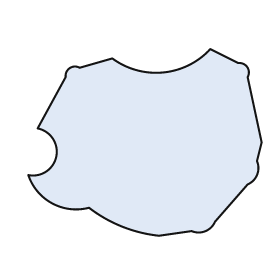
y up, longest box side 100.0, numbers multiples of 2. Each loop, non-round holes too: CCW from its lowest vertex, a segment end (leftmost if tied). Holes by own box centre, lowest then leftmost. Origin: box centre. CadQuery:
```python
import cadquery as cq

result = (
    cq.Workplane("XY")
    .moveTo(6.0, -40.0)
    .lineTo(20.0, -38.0)
    .threePointArc((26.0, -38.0), (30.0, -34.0))
    .lineTo(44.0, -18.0)
    .threePointArc((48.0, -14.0), (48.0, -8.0))
    .lineTo(50.0, 0.0)
    .lineTo(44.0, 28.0)
    .threePointArc((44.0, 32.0), (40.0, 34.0))
    .lineTo(28.0, 40.0)
    .threePointArc((8.0, 30.0), (-14.0, 36.0))
    .lineTo(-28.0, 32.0)
    .threePointArc((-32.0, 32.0), (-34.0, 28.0))
    .lineTo(-46.0, 6.0)
    .threePointArc((-38.0, -6.0), (-50.0, -14.0))
    .threePointArc((-40.0, -26.0), (-24.0, -28.0))
    .threePointArc((-10.0, -36.0), (6.0, -40.0))
    .close()
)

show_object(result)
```